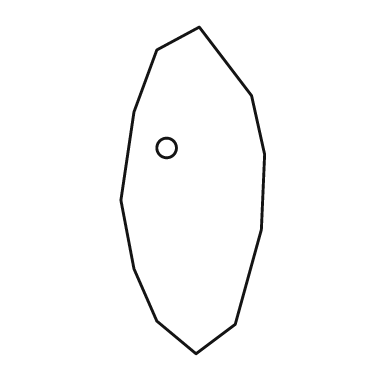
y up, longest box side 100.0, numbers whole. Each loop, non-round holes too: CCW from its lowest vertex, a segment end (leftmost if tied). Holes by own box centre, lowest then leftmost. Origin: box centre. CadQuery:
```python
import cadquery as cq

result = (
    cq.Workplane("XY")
    .moveTo(1.0, -50.0)
    .lineTo(13.0, -41.0)
    .lineTo(21.0, -12.0)
    .lineTo(22.0, 11.0)
    .lineTo(18.0, 29.0)
    .lineTo(2.0, 50.0)
    .lineTo(-11.0, 43.0)
    .lineTo(-18.0, 24.0)
    .lineTo(-22.0, -3.0)
    .lineTo(-18.0, -24.0)
    .lineTo(-11.0, -40.0)
    .close()
    .moveTo(-8.0, 13.0)
    .circle(3.0)
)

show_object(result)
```